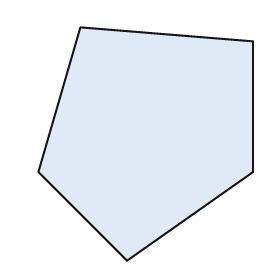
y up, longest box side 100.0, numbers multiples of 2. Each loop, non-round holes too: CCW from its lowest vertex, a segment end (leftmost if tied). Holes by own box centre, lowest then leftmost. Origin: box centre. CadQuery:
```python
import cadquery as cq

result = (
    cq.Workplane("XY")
    .moveTo(-8.0, -50.0)
    .lineTo(46.0, -12.0)
    .lineTo(46.0, 44.0)
    .lineTo(-28.0, 50.0)
    .lineTo(-46.0, -12.0)
    .close()
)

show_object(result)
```